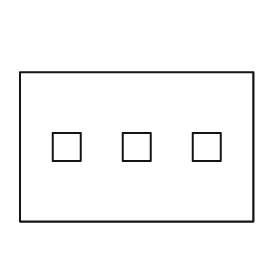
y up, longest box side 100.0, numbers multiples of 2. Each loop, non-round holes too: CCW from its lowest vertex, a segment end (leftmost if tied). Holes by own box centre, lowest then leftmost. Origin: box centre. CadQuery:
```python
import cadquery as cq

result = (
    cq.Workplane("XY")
    .moveTo(-50.0, -32.0)
    .lineTo(50.0, -32.0)
    .lineTo(50.0, 32.0)
    .lineTo(-50.0, 32.0)
    .close()
    .moveTo(-36.0, -6.0)
    .lineTo(-24.0, -6.0)
    .lineTo(-24.0, 6.0)
    .lineTo(-36.0, 6.0)
    .close()
    .moveTo(-6.0, -6.0)
    .lineTo(6.0, -6.0)
    .lineTo(6.0, 6.0)
    .lineTo(-6.0, 6.0)
    .close()
    .moveTo(24.0, -6.0)
    .lineTo(36.0, -6.0)
    .lineTo(36.0, 6.0)
    .lineTo(24.0, 6.0)
    .close()
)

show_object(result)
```